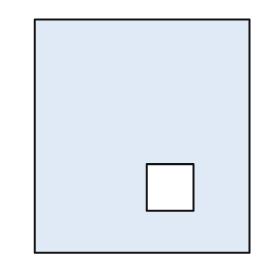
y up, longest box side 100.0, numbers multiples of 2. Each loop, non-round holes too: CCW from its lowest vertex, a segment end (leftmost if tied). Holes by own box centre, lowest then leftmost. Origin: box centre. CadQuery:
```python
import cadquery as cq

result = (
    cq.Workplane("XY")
    .moveTo(-46.0, -50.0)
    .lineTo(46.0, -50.0)
    .lineTo(46.0, 50.0)
    .lineTo(-46.0, 50.0)
    .close()
    .moveTo(2.0, -32.0)
    .lineTo(22.0, -32.0)
    .lineTo(22.0, -12.0)
    .lineTo(2.0, -12.0)
    .close()
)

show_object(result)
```